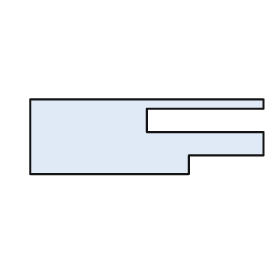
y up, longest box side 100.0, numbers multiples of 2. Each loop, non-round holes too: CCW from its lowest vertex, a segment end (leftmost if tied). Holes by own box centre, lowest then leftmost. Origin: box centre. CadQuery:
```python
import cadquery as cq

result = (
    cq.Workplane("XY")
    .moveTo(-50.0, -16.0)
    .lineTo(18.0, -16.0)
    .lineTo(18.0, -8.0)
    .lineTo(50.0, -8.0)
    .lineTo(50.0, 2.0)
    .lineTo(0.0, 2.0)
    .lineTo(0.0, 12.0)
    .lineTo(50.0, 12.0)
    .lineTo(50.0, 16.0)
    .lineTo(-50.0, 16.0)
    .close()
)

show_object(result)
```